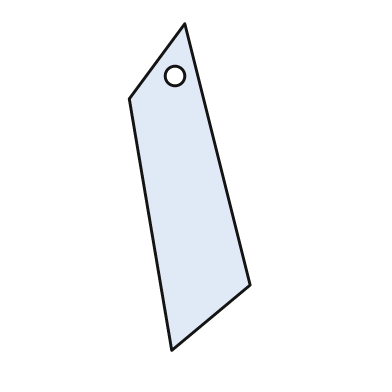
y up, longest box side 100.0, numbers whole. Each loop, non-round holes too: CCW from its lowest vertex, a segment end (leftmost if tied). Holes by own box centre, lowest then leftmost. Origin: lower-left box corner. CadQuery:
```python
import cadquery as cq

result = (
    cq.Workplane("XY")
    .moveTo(13.0, 0.0)
    .lineTo(37.0, 20.0)
    .lineTo(17.0, 100.0)
    .lineTo(0.0, 77.0)
    .close()
    .moveTo(14.0, 84.0)
    .circle(3.0)
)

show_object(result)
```